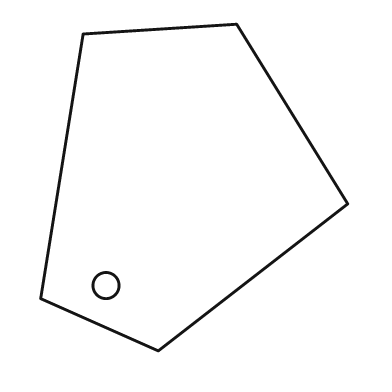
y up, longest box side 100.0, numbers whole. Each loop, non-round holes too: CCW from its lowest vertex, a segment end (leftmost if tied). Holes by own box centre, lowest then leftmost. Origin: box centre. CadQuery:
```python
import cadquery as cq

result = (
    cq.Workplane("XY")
    .moveTo(-11.0, -50.0)
    .lineTo(47.0, -5.0)
    .lineTo(13.0, 50.0)
    .lineTo(-34.0, 47.0)
    .lineTo(-47.0, -34.0)
    .close()
    .moveTo(-27.0, -30.0)
    .circle(4.0)
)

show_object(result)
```